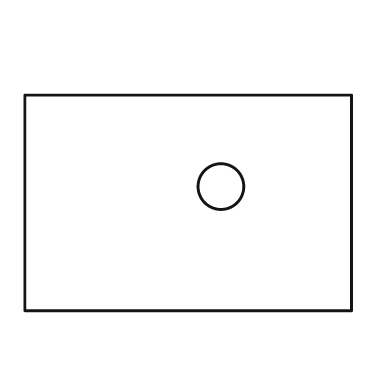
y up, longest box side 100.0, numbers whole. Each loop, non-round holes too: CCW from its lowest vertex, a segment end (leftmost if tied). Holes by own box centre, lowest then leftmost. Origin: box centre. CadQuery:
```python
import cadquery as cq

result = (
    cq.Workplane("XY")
    .moveTo(-50.0, -33.0)
    .lineTo(50.0, -33.0)
    .lineTo(50.0, 33.0)
    .lineTo(-50.0, 33.0)
    .close()
    .moveTo(10.0, 5.0)
    .circle(7.0)
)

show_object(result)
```